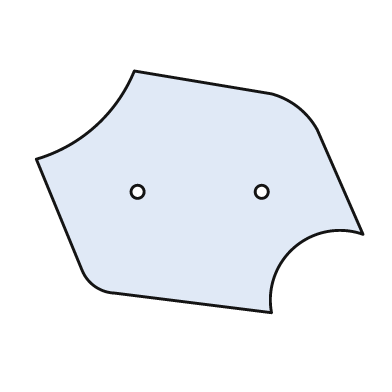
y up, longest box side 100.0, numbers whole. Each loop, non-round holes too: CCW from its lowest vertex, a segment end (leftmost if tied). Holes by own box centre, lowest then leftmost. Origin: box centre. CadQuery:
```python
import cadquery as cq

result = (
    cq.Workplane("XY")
    .moveTo(22.0, -37.0)
    .threePointArc((29.0, -17.0), (50.0, -13.0))
    .lineTo(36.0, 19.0)
    .threePointArc((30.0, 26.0), (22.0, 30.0))
    .lineTo(-20.0, 37.0)
    .threePointArc((-32.0, 20.0), (-50.0, 10.0))
    .lineTo(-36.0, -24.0)
    .threePointArc((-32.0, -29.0), (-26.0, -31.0))
    .close()
    .moveTo(-19.0, 0.0)
    .circle(2.0)
    .moveTo(19.0, 0.0)
    .circle(2.0)
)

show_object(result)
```